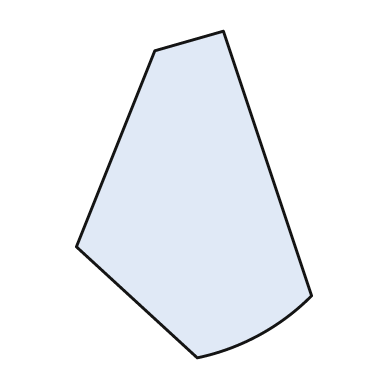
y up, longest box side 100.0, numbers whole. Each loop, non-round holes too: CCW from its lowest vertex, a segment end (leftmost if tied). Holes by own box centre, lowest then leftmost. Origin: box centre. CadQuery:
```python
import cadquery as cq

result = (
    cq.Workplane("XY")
    .moveTo(1.0, -50.0)
    .threePointArc((20.0, -43.0), (36.0, -31.0))
    .lineTo(9.0, 50.0)
    .lineTo(-12.0, 44.0)
    .lineTo(-36.0, -16.0)
    .close()
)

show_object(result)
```